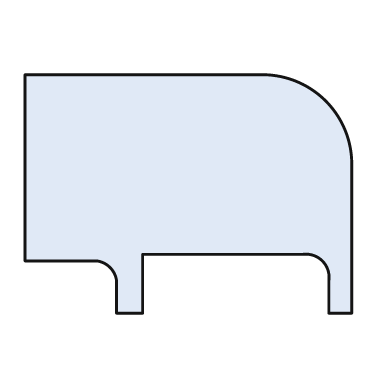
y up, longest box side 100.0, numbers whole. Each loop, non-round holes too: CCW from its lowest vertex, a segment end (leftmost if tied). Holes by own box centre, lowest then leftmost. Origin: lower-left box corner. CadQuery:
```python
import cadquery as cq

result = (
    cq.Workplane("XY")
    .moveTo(28.0, 0.0)
    .lineTo(36.0, 0.0)
    .lineTo(36.0, 18.0)
    .lineTo(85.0, 18.0)
    .threePointArc((91.0, 16.0), (93.0, 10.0))
    .lineTo(93.0, 0.0)
    .lineTo(100.0, 0.0)
    .lineTo(100.0, 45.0)
    .threePointArc((92.0, 65.0), (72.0, 73.0))
    .lineTo(0.0, 73.0)
    .lineTo(0.0, 16.0)
    .lineTo(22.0, 16.0)
    .threePointArc((26.0, 14.0), (28.0, 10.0))
    .close()
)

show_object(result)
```